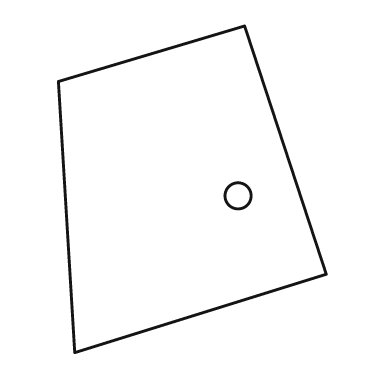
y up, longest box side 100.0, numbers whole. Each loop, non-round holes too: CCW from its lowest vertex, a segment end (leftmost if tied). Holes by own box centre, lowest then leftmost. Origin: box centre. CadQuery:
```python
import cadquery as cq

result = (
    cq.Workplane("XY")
    .moveTo(-36.0, -50.0)
    .lineTo(41.0, -26.0)
    .lineTo(16.0, 50.0)
    .lineTo(-41.0, 33.0)
    .close()
    .moveTo(14.0, -2.0)
    .circle(4.0)
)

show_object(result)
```